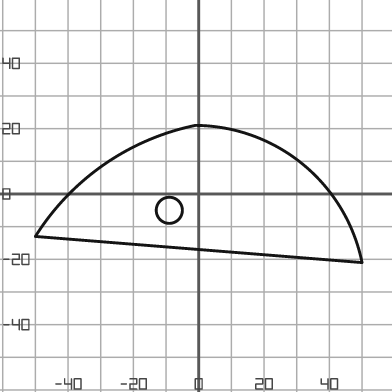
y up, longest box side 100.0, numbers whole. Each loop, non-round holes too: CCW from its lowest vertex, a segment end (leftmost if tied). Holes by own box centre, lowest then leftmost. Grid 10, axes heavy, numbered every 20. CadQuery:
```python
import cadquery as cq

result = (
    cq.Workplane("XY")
    .moveTo(50.0, -21.0)
    .threePointArc((32.0, 9.0), (-1.0, 21.0))
    .threePointArc((-29.0, 9.0), (-50.0, -13.0))
    .close()
    .moveTo(-9.0, -5.0)
    .circle(4.0)
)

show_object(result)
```